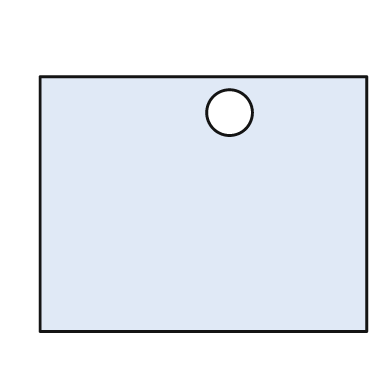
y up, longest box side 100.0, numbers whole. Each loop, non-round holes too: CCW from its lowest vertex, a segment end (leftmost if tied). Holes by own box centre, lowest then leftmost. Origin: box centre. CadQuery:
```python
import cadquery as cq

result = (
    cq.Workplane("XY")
    .moveTo(-50.0, -39.0)
    .lineTo(50.0, -39.0)
    .lineTo(50.0, 39.0)
    .lineTo(-50.0, 39.0)
    .close()
    .moveTo(8.0, 28.0)
    .circle(7.0)
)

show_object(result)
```